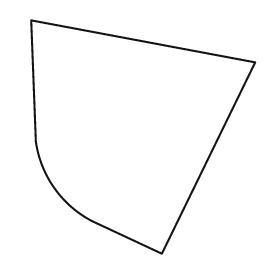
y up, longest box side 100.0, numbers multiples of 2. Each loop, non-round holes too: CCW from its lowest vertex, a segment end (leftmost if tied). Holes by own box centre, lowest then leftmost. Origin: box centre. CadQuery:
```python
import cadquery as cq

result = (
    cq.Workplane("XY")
    .moveTo(8.0, -50.0)
    .lineTo(48.0, 32.0)
    .lineTo(-48.0, 50.0)
    .lineTo(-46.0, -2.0)
    .threePointArc((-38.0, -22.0), (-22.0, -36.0))
    .close()
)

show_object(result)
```